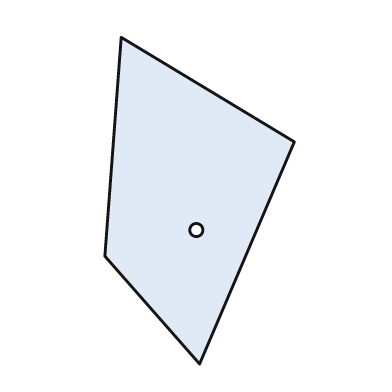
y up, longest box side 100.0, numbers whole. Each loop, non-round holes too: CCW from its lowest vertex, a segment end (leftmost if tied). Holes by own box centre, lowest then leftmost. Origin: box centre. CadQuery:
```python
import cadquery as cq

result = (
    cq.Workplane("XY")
    .moveTo(0.0, -50.0)
    .lineTo(29.0, 18.0)
    .lineTo(-24.0, 50.0)
    .lineTo(-29.0, -17.0)
    .close()
    .moveTo(-1.0, -9.0)
    .circle(2.0)
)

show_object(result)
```